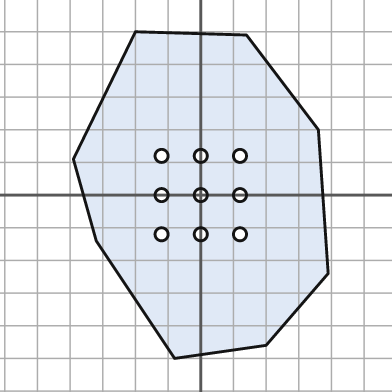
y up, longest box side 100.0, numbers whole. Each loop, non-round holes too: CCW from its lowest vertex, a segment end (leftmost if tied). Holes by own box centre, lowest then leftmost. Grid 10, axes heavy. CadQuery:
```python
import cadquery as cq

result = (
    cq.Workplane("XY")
    .moveTo(-8.0, -50.0)
    .lineTo(20.0, -46.0)
    .lineTo(39.0, -24.0)
    .lineTo(36.0, 20.0)
    .lineTo(14.0, 49.0)
    .lineTo(-20.0, 50.0)
    .lineTo(-39.0, 11.0)
    .lineTo(-32.0, -14.0)
    .close()
    .moveTo(-12.0, -12.0)
    .circle(2.0)
    .moveTo(0.0, -12.0)
    .circle(2.0)
    .moveTo(12.0, -12.0)
    .circle(2.0)
    .moveTo(-12.0, 0.0)
    .circle(2.0)
    .moveTo(0.0, 0.0)
    .circle(2.0)
    .moveTo(12.0, 0.0)
    .circle(2.0)
    .moveTo(-12.0, 12.0)
    .circle(2.0)
    .moveTo(0.0, 12.0)
    .circle(2.0)
    .moveTo(12.0, 12.0)
    .circle(2.0)
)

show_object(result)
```